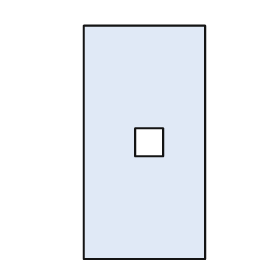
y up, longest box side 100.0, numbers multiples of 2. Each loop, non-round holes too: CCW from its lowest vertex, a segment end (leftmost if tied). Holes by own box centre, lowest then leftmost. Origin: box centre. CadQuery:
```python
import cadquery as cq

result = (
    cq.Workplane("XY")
    .moveTo(-26.0, -50.0)
    .lineTo(26.0, -50.0)
    .lineTo(26.0, 50.0)
    .lineTo(-26.0, 50.0)
    .close()
    .moveTo(-4.0, -6.0)
    .lineTo(8.0, -6.0)
    .lineTo(8.0, 6.0)
    .lineTo(-4.0, 6.0)
    .close()
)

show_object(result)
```